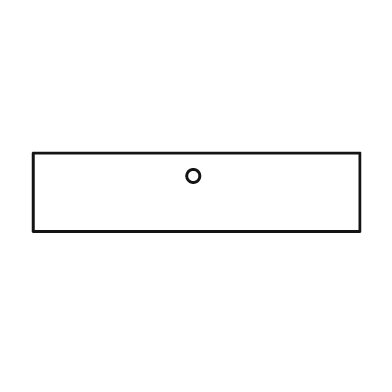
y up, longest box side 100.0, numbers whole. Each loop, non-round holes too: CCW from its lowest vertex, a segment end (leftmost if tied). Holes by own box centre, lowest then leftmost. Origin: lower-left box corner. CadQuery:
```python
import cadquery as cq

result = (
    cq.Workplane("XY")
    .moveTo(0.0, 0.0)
    .lineTo(100.0, 0.0)
    .lineTo(100.0, 24.0)
    .lineTo(0.0, 24.0)
    .close()
    .moveTo(49.0, 17.0)
    .circle(2.0)
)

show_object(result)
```